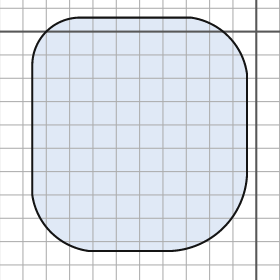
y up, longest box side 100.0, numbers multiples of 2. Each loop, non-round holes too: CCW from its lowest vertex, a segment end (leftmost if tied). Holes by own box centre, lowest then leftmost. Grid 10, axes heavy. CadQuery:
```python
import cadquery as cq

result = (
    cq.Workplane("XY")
    .moveTo(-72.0, -94.0)
    .lineTo(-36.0, -94.0)
    .threePointArc((-14.0, -84.0), (-4.0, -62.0))
    .lineTo(-4.0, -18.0)
    .threePointArc((-12.0, -2.0), (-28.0, 6.0))
    .lineTo(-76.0, 6.0)
    .threePointArc((-90.0, 0.0), (-96.0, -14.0))
    .lineTo(-96.0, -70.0)
    .threePointArc((-88.0, -86.0), (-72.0, -94.0))
    .close()
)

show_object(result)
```